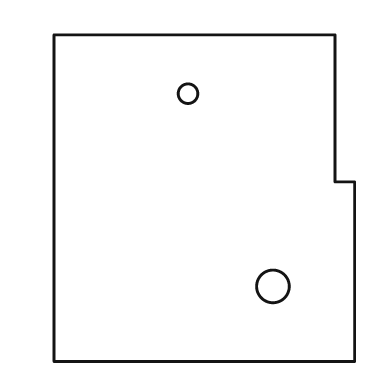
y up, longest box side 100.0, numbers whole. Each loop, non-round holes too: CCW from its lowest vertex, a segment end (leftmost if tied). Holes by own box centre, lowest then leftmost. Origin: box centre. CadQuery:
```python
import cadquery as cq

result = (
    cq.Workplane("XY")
    .moveTo(-46.0, -50.0)
    .lineTo(46.0, -50.0)
    .lineTo(46.0, 5.0)
    .lineTo(40.0, 5.0)
    .lineTo(40.0, 50.0)
    .lineTo(-46.0, 50.0)
    .close()
    .moveTo(21.0, -27.0)
    .circle(5.0)
    .moveTo(-5.0, 32.0)
    .circle(3.0)
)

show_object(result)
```